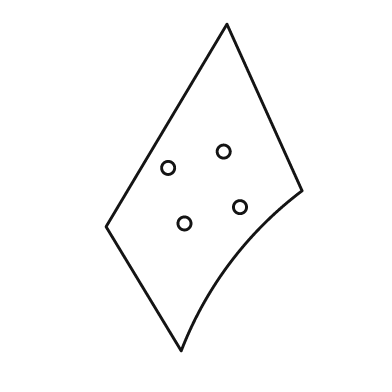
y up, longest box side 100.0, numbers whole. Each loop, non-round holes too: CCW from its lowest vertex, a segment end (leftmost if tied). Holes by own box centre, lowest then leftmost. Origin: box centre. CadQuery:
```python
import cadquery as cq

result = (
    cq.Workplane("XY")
    .moveTo(-7.0, -50.0)
    .threePointArc((8.0, -23.0), (30.0, -1.0))
    .lineTo(7.0, 50.0)
    .lineTo(-30.0, -12.0)
    .close()
    .moveTo(-6.0, -11.0)
    .circle(2.0)
    .moveTo(11.0, -6.0)
    .circle(2.0)
    .moveTo(-11.0, 6.0)
    .circle(2.0)
    .moveTo(6.0, 11.0)
    .circle(2.0)
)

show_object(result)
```